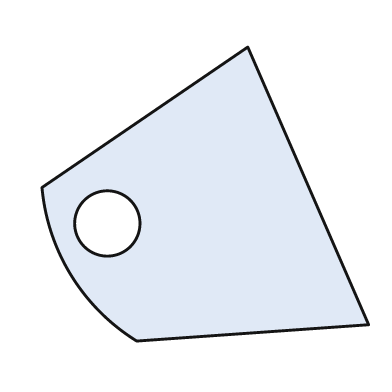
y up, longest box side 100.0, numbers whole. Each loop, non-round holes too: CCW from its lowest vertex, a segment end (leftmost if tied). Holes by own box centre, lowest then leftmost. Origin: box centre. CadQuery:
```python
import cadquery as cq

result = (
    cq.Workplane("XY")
    .moveTo(-21.0, -45.0)
    .lineTo(50.0, -40.0)
    .lineTo(13.0, 45.0)
    .lineTo(-50.0, 2.0)
    .threePointArc((-41.0, -25.0), (-21.0, -45.0))
    .close()
    .moveTo(-30.0, -9.0)
    .circle(10.0)
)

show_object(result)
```